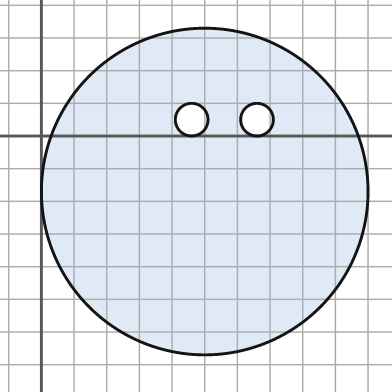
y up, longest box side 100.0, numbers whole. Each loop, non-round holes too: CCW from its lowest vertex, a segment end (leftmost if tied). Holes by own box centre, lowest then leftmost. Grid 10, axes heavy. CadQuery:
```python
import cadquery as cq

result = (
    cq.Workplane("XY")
    .moveTo(50.0, -17.0)
    .circle(50.0)
    .moveTo(46.0, 5.0)
    .circle(5.0)
    .moveTo(66.0, 5.0)
    .circle(5.0)
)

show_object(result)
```